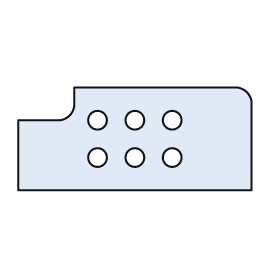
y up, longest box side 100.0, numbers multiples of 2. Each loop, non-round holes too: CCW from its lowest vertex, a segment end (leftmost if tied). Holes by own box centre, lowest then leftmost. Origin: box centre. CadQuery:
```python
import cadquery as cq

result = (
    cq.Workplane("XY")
    .moveTo(-50.0, -22.0)
    .lineTo(50.0, -22.0)
    .lineTo(50.0, 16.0)
    .threePointArc((48.0, 20.0), (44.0, 22.0))
    .lineTo(-26.0, 22.0)
    .lineTo(-26.0, 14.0)
    .threePointArc((-28.0, 10.0), (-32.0, 8.0))
    .lineTo(-50.0, 8.0)
    .close()
    .moveTo(-16.0, -8.0)
    .circle(4.0)
    .moveTo(0.0, -8.0)
    .circle(4.0)
    .moveTo(16.0, -8.0)
    .circle(4.0)
    .moveTo(-16.0, 8.0)
    .circle(4.0)
    .moveTo(0.0, 8.0)
    .circle(4.0)
    .moveTo(16.0, 8.0)
    .circle(4.0)
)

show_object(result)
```